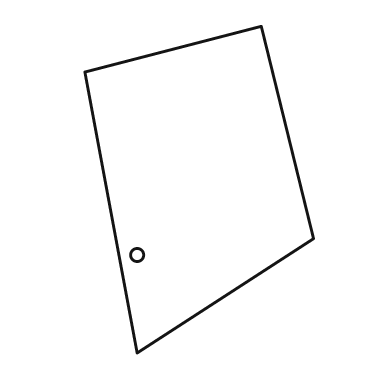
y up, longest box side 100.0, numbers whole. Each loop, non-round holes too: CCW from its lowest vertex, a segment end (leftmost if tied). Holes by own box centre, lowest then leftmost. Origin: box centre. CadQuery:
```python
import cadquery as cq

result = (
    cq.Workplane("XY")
    .moveTo(-19.0, -50.0)
    .lineTo(35.0, -15.0)
    .lineTo(19.0, 50.0)
    .lineTo(-35.0, 36.0)
    .close()
    .moveTo(-19.0, -20.0)
    .circle(2.0)
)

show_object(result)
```